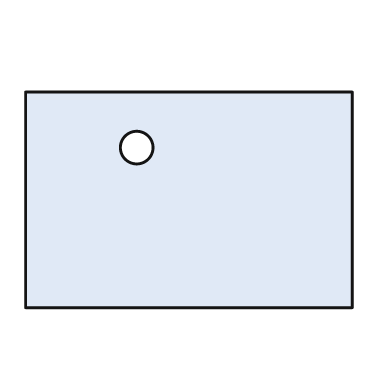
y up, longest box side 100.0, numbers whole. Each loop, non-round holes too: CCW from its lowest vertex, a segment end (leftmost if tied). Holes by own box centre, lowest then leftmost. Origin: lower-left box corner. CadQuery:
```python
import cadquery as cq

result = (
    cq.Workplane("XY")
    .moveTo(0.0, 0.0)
    .lineTo(100.0, 0.0)
    .lineTo(100.0, 66.0)
    .lineTo(0.0, 66.0)
    .close()
    .moveTo(34.0, 49.0)
    .circle(5.0)
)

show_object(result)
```